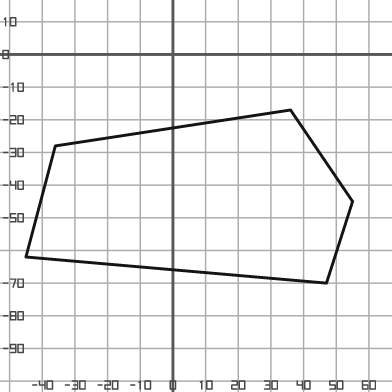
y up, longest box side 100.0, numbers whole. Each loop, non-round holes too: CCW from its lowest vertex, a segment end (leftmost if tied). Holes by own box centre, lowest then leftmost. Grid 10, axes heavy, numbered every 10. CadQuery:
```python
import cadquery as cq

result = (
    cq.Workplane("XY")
    .moveTo(47.0, -70.0)
    .lineTo(55.0, -45.0)
    .lineTo(36.0, -17.0)
    .lineTo(-36.0, -28.0)
    .lineTo(-45.0, -62.0)
    .close()
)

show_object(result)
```